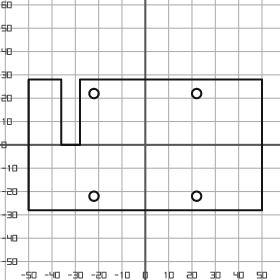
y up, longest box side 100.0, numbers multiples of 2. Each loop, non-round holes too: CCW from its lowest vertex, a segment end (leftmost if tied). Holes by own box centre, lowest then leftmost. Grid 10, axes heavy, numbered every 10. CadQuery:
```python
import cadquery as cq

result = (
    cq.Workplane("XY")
    .moveTo(-50.0, -28.0)
    .lineTo(50.0, -28.0)
    .lineTo(50.0, 28.0)
    .lineTo(-28.0, 28.0)
    .lineTo(-28.0, 0.0)
    .lineTo(-36.0, 0.0)
    .lineTo(-36.0, 28.0)
    .lineTo(-50.0, 28.0)
    .close()
    .moveTo(-22.0, -22.0)
    .circle(2.0)
    .moveTo(22.0, -22.0)
    .circle(2.0)
    .moveTo(-22.0, 22.0)
    .circle(2.0)
    .moveTo(22.0, 22.0)
    .circle(2.0)
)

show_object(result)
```